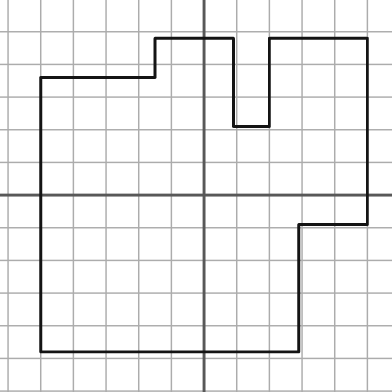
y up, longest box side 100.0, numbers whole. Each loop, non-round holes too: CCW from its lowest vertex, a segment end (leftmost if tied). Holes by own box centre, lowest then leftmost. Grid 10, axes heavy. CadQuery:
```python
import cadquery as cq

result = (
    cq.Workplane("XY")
    .moveTo(-50.0, -48.0)
    .lineTo(29.0, -48.0)
    .lineTo(29.0, -9.0)
    .lineTo(50.0, -9.0)
    .lineTo(50.0, 48.0)
    .lineTo(20.0, 48.0)
    .lineTo(20.0, 21.0)
    .lineTo(9.0, 21.0)
    .lineTo(9.0, 48.0)
    .lineTo(-15.0, 48.0)
    .lineTo(-15.0, 36.0)
    .lineTo(-50.0, 36.0)
    .close()
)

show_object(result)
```